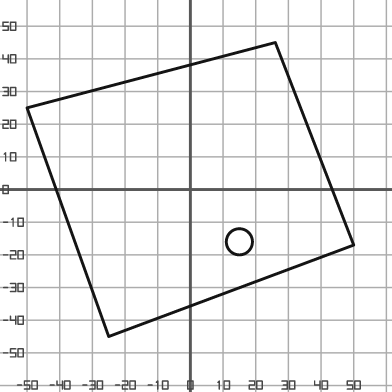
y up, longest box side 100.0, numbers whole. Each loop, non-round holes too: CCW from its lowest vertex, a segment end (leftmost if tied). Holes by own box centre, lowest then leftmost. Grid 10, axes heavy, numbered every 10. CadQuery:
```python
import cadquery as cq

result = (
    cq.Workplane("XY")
    .moveTo(-25.0, -45.0)
    .lineTo(50.0, -17.0)
    .lineTo(26.0, 45.0)
    .lineTo(-50.0, 25.0)
    .close()
    .moveTo(15.0, -16.0)
    .circle(4.0)
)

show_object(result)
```